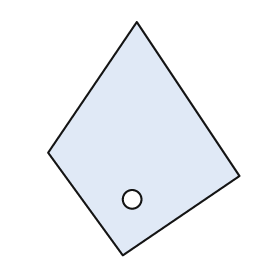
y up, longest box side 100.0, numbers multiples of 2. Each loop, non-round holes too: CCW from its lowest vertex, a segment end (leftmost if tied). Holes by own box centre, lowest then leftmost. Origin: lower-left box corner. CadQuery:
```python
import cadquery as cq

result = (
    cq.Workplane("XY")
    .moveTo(32.0, 0.0)
    .lineTo(82.0, 34.0)
    .lineTo(38.0, 100.0)
    .lineTo(0.0, 44.0)
    .close()
    .moveTo(36.0, 24.0)
    .circle(4.0)
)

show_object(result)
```